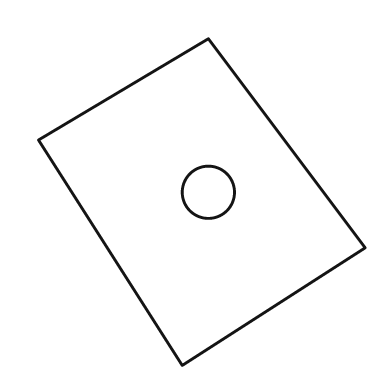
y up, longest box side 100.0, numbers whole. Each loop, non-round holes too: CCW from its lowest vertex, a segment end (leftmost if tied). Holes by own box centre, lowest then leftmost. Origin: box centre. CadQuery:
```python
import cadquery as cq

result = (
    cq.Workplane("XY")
    .moveTo(-6.0, -50.0)
    .lineTo(50.0, -14.0)
    .lineTo(2.0, 50.0)
    .lineTo(-50.0, 19.0)
    .close()
    .moveTo(2.0, 3.0)
    .circle(8.0)
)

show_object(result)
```